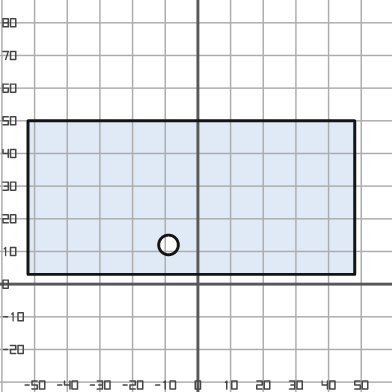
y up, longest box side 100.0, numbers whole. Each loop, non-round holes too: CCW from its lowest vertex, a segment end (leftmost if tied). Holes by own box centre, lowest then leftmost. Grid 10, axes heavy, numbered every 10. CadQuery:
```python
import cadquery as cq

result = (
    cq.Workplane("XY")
    .moveTo(-52.0, 3.0)
    .lineTo(48.0, 3.0)
    .lineTo(48.0, 50.0)
    .lineTo(-52.0, 50.0)
    .close()
    .moveTo(-9.0, 12.0)
    .circle(3.0)
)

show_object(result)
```